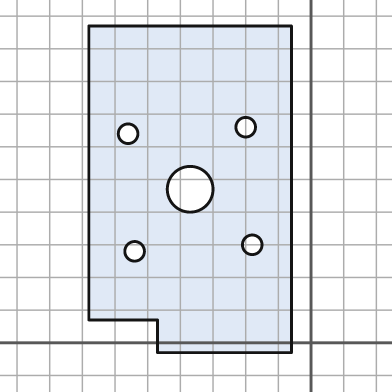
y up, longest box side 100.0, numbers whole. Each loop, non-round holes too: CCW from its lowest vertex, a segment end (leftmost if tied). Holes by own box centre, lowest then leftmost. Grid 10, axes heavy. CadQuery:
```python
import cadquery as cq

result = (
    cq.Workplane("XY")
    .moveTo(-47.0, -3.0)
    .lineTo(-6.0, -3.0)
    .lineTo(-6.0, 97.0)
    .lineTo(-68.0, 97.0)
    .lineTo(-68.0, 7.0)
    .lineTo(-47.0, 7.0)
    .close()
    .moveTo(-54.0, 28.0)
    .circle(3.0)
    .moveTo(-18.0, 30.0)
    .circle(3.0)
    .moveTo(-37.0, 47.0)
    .circle(7.0)
    .moveTo(-56.0, 64.0)
    .circle(3.0)
    .moveTo(-20.0, 66.0)
    .circle(3.0)
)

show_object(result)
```